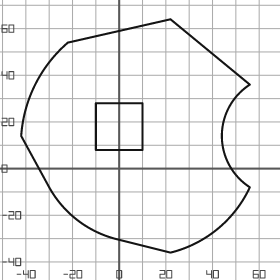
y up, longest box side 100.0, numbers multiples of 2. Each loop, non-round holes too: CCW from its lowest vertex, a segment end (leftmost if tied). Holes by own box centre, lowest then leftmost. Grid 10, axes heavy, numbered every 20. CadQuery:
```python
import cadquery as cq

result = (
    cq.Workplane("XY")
    .moveTo(22.0, -36.0)
    .threePointArc((42.0, -26.0), (56.0, -8.0))
    .threePointArc((44.0, 14.0), (56.0, 36.0))
    .lineTo(22.0, 64.0)
    .lineTo(-22.0, 54.0)
    .threePointArc((-36.0, 36.0), (-42.0, 14.0))
    .lineTo(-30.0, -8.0)
    .threePointArc((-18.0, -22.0), (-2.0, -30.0))
    .close()
    .moveTo(-10.0, 8.0)
    .lineTo(10.0, 8.0)
    .lineTo(10.0, 28.0)
    .lineTo(-10.0, 28.0)
    .close()
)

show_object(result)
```